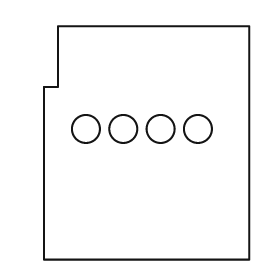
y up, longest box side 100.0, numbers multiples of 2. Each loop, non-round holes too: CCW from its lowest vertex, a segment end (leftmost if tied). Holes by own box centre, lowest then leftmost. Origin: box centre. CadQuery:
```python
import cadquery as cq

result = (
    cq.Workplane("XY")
    .moveTo(-44.0, -50.0)
    .lineTo(44.0, -50.0)
    .lineTo(44.0, 50.0)
    .lineTo(-38.0, 50.0)
    .lineTo(-38.0, 24.0)
    .lineTo(-44.0, 24.0)
    .close()
    .moveTo(-26.0, 6.0)
    .circle(6.0)
    .moveTo(-10.0, 6.0)
    .circle(6.0)
    .moveTo(6.0, 6.0)
    .circle(6.0)
    .moveTo(22.0, 6.0)
    .circle(6.0)
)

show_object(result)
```